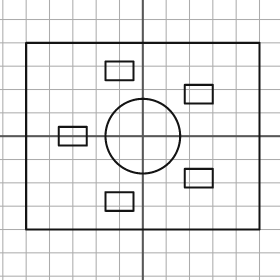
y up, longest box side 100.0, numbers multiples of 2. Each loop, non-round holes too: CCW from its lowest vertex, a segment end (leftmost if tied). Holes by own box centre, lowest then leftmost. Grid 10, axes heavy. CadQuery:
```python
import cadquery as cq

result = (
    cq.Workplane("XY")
    .moveTo(-50.0, -40.0)
    .lineTo(50.0, -40.0)
    .lineTo(50.0, 40.0)
    .lineTo(-50.0, 40.0)
    .close()
    .moveTo(-16.0, -32.0)
    .lineTo(-4.0, -32.0)
    .lineTo(-4.0, -24.0)
    .lineTo(-16.0, -24.0)
    .close()
    .moveTo(18.0, -22.0)
    .lineTo(30.0, -22.0)
    .lineTo(30.0, -14.0)
    .lineTo(18.0, -14.0)
    .close()
    .moveTo(-36.0, -4.0)
    .lineTo(-24.0, -4.0)
    .lineTo(-24.0, 4.0)
    .lineTo(-36.0, 4.0)
    .close()
    .moveTo(0.0, 0.0)
    .circle(16.0)
    .moveTo(18.0, 14.0)
    .lineTo(30.0, 14.0)
    .lineTo(30.0, 22.0)
    .lineTo(18.0, 22.0)
    .close()
    .moveTo(-16.0, 24.0)
    .lineTo(-4.0, 24.0)
    .lineTo(-4.0, 32.0)
    .lineTo(-16.0, 32.0)
    .close()
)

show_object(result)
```